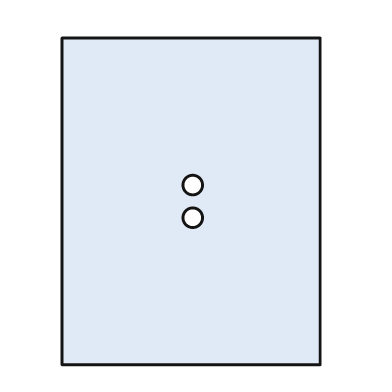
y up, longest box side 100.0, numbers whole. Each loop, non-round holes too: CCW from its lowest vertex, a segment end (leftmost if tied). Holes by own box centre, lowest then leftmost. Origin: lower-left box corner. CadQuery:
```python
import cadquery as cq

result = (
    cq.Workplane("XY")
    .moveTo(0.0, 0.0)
    .lineTo(79.0, 0.0)
    .lineTo(79.0, 100.0)
    .lineTo(0.0, 100.0)
    .close()
    .moveTo(40.0, 45.0)
    .circle(3.0)
    .moveTo(40.0, 55.0)
    .circle(3.0)
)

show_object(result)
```